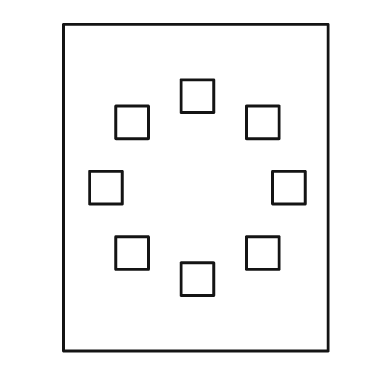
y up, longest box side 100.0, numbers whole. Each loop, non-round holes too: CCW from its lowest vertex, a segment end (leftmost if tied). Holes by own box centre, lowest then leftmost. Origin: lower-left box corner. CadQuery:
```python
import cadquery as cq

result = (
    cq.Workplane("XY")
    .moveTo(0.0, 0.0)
    .lineTo(81.0, 0.0)
    .lineTo(81.0, 100.0)
    .lineTo(0.0, 100.0)
    .close()
    .moveTo(36.0, 17.0)
    .lineTo(46.0, 17.0)
    .lineTo(46.0, 27.0)
    .lineTo(36.0, 27.0)
    .close()
    .moveTo(16.0, 25.0)
    .lineTo(26.0, 25.0)
    .lineTo(26.0, 35.0)
    .lineTo(16.0, 35.0)
    .close()
    .moveTo(56.0, 25.0)
    .lineTo(66.0, 25.0)
    .lineTo(66.0, 35.0)
    .lineTo(56.0, 35.0)
    .close()
    .moveTo(8.0, 45.0)
    .lineTo(18.0, 45.0)
    .lineTo(18.0, 55.0)
    .lineTo(8.0, 55.0)
    .close()
    .moveTo(64.0, 45.0)
    .lineTo(74.0, 45.0)
    .lineTo(74.0, 55.0)
    .lineTo(64.0, 55.0)
    .close()
    .moveTo(16.0, 65.0)
    .lineTo(26.0, 65.0)
    .lineTo(26.0, 75.0)
    .lineTo(16.0, 75.0)
    .close()
    .moveTo(56.0, 65.0)
    .lineTo(66.0, 65.0)
    .lineTo(66.0, 75.0)
    .lineTo(56.0, 75.0)
    .close()
    .moveTo(36.0, 73.0)
    .lineTo(46.0, 73.0)
    .lineTo(46.0, 83.0)
    .lineTo(36.0, 83.0)
    .close()
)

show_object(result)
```